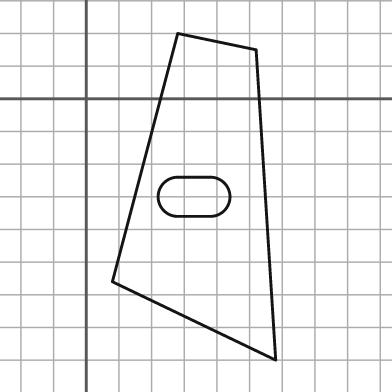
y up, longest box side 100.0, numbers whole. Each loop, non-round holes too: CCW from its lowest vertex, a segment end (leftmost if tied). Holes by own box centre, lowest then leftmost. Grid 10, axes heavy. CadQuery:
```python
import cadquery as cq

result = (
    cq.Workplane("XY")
    .moveTo(58.0, -80.0)
    .lineTo(52.0, 15.0)
    .lineTo(28.0, 20.0)
    .lineTo(8.0, -56.0)
    .close()
    .moveTo(28.0, -36.0)
    .lineTo(38.0, -36.0)
    .threePointArc((44.0, -30.0), (38.0, -24.0))
    .lineTo(28.0, -24.0)
    .threePointArc((22.0, -30.0), (28.0, -36.0))
    .close()
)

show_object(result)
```